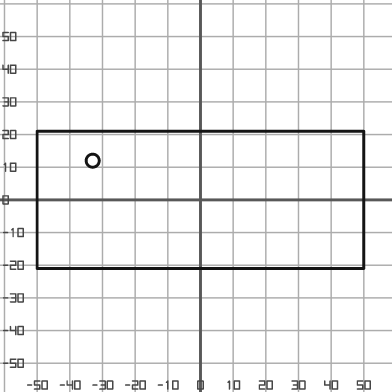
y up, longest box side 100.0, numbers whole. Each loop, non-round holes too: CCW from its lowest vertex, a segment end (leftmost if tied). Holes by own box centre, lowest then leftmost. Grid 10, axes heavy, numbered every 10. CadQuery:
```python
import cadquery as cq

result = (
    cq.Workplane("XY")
    .moveTo(-50.0, -21.0)
    .lineTo(50.0, -21.0)
    .lineTo(50.0, 21.0)
    .lineTo(-50.0, 21.0)
    .close()
    .moveTo(-33.0, 12.0)
    .circle(2.0)
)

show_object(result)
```